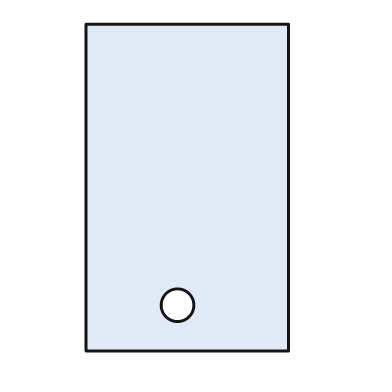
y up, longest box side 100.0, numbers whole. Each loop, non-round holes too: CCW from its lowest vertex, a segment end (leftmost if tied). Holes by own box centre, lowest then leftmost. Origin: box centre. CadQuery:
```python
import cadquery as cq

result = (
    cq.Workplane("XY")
    .moveTo(-31.0, -50.0)
    .lineTo(31.0, -50.0)
    .lineTo(31.0, 50.0)
    .lineTo(-31.0, 50.0)
    .close()
    .moveTo(-3.0, -36.0)
    .circle(5.0)
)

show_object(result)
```